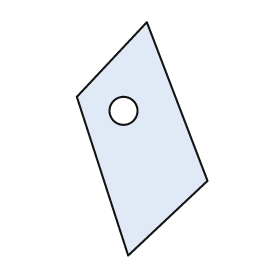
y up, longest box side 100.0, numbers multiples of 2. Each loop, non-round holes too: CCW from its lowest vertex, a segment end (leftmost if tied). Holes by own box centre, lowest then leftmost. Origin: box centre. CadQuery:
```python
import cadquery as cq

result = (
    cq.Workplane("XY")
    .moveTo(-6.0, -50.0)
    .lineTo(28.0, -18.0)
    .lineTo(2.0, 50.0)
    .lineTo(-28.0, 18.0)
    .close()
    .moveTo(-8.0, 12.0)
    .circle(6.0)
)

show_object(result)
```